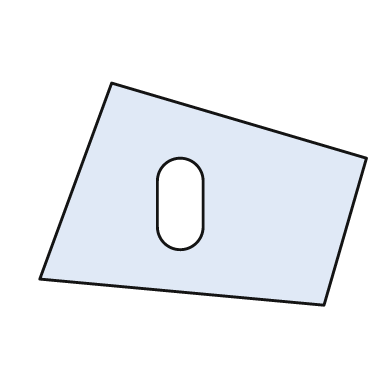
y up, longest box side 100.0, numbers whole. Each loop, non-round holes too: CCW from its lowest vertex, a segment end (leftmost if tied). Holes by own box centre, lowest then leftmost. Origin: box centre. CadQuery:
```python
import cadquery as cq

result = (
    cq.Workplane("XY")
    .moveTo(37.0, -34.0)
    .lineTo(50.0, 11.0)
    .lineTo(-28.0, 34.0)
    .lineTo(-50.0, -26.0)
    .close()
    .moveTo(-14.0, -10.0)
    .threePointArc((-7.0, -17.0), (0.0, -10.0))
    .lineTo(0.0, 4.0)
    .threePointArc((-7.0, 11.0), (-14.0, 4.0))
    .close()
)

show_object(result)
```